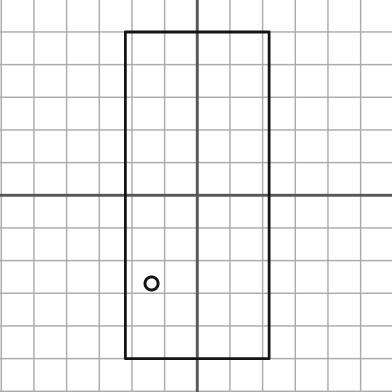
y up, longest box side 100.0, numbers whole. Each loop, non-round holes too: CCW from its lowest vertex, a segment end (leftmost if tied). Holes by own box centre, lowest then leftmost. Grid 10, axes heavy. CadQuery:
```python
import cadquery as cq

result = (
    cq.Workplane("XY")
    .moveTo(-22.0, -50.0)
    .lineTo(22.0, -50.0)
    .lineTo(22.0, 50.0)
    .lineTo(-22.0, 50.0)
    .close()
    .moveTo(-14.0, -27.0)
    .circle(2.0)
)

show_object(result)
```